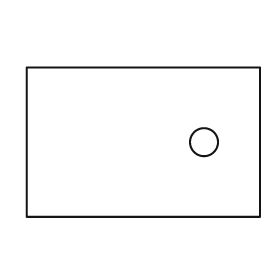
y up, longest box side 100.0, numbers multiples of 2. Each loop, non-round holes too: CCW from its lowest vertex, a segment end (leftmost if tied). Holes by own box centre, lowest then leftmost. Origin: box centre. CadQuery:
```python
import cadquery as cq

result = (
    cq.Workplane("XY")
    .moveTo(-50.0, -32.0)
    .lineTo(50.0, -32.0)
    .lineTo(50.0, 32.0)
    .lineTo(-50.0, 32.0)
    .close()
    .moveTo(26.0, 0.0)
    .circle(6.0)
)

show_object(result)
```